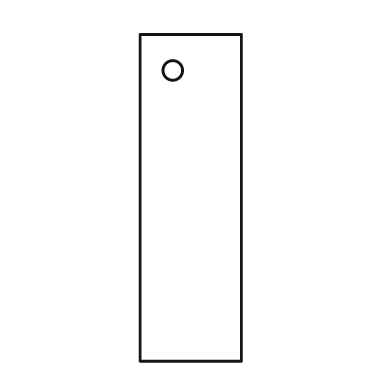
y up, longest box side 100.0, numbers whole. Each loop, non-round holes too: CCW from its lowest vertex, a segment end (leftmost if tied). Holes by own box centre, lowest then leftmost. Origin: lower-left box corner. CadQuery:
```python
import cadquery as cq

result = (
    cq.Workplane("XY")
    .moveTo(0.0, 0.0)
    .lineTo(31.0, 0.0)
    .lineTo(31.0, 100.0)
    .lineTo(0.0, 100.0)
    .close()
    .moveTo(10.0, 89.0)
    .circle(3.0)
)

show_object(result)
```